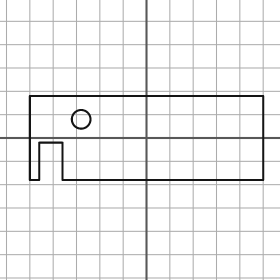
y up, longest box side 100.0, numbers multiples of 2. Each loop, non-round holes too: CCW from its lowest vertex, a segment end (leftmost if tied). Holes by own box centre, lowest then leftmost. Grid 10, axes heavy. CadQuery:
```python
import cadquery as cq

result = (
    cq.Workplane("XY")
    .moveTo(-50.0, -18.0)
    .lineTo(-46.0, -18.0)
    .lineTo(-46.0, -2.0)
    .lineTo(-36.0, -2.0)
    .lineTo(-36.0, -18.0)
    .lineTo(50.0, -18.0)
    .lineTo(50.0, 18.0)
    .lineTo(-50.0, 18.0)
    .close()
    .moveTo(-28.0, 8.0)
    .circle(4.0)
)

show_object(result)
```